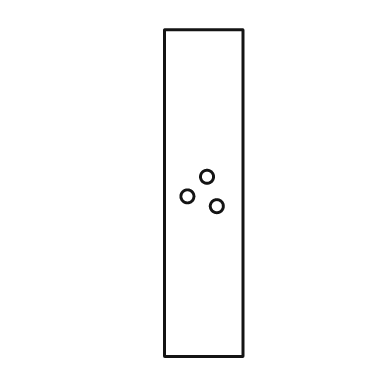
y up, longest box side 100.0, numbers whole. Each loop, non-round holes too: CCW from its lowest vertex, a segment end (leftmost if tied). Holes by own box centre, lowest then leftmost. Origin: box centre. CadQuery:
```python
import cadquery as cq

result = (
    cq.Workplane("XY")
    .moveTo(-12.0, -50.0)
    .lineTo(12.0, -50.0)
    .lineTo(12.0, 50.0)
    .lineTo(-12.0, 50.0)
    .close()
    .moveTo(4.0, -4.0)
    .circle(2.0)
    .moveTo(-5.0, -1.0)
    .circle(2.0)
    .moveTo(1.0, 5.0)
    .circle(2.0)
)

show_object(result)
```